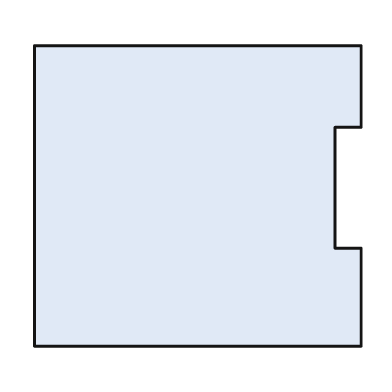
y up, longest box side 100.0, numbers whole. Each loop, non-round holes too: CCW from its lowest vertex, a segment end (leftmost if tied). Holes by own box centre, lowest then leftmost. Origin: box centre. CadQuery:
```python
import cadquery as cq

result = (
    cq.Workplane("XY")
    .moveTo(-50.0, -46.0)
    .lineTo(50.0, -46.0)
    .lineTo(50.0, -16.0)
    .lineTo(42.0, -16.0)
    .lineTo(42.0, 21.0)
    .lineTo(50.0, 21.0)
    .lineTo(50.0, 46.0)
    .lineTo(-50.0, 46.0)
    .close()
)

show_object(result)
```